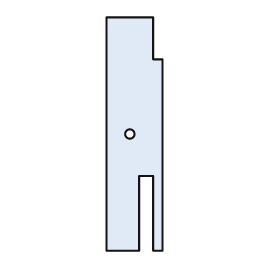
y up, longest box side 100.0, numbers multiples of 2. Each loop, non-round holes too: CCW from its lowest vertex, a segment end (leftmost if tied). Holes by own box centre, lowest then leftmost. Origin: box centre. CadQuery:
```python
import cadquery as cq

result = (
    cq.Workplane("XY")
    .moveTo(-12.0, -50.0)
    .lineTo(2.0, -50.0)
    .lineTo(2.0, -18.0)
    .lineTo(8.0, -18.0)
    .lineTo(8.0, -50.0)
    .lineTo(12.0, -50.0)
    .lineTo(12.0, 32.0)
    .lineTo(8.0, 32.0)
    .lineTo(8.0, 50.0)
    .lineTo(-12.0, 50.0)
    .close()
    .moveTo(-2.0, 0.0)
    .circle(2.0)
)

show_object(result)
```